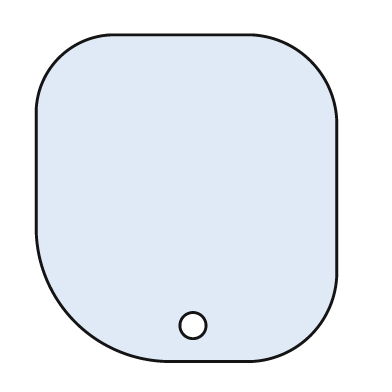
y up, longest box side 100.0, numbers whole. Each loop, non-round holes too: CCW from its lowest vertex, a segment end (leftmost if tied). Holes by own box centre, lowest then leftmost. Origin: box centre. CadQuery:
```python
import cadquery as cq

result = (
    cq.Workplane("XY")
    .moveTo(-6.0, -50.0)
    .lineTo(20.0, -50.0)
    .threePointArc((38.0, -42.0), (46.0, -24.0))
    .lineTo(46.0, 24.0)
    .threePointArc((38.0, 42.0), (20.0, 50.0))
    .lineTo(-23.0, 50.0)
    .threePointArc((-39.0, 43.0), (-46.0, 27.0))
    .lineTo(-46.0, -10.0)
    .threePointArc((-34.0, -38.0), (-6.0, -50.0))
    .close()
    .moveTo(2.0, -39.0)
    .circle(4.0)
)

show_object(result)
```